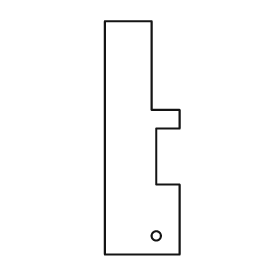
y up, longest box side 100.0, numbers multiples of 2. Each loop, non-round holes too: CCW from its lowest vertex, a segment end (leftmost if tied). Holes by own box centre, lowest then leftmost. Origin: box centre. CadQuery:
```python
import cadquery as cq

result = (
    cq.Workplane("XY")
    .moveTo(-16.0, -50.0)
    .lineTo(16.0, -50.0)
    .lineTo(16.0, -20.0)
    .lineTo(6.0, -20.0)
    .lineTo(6.0, 4.0)
    .lineTo(16.0, 4.0)
    .lineTo(16.0, 12.0)
    .lineTo(4.0, 12.0)
    .lineTo(4.0, 50.0)
    .lineTo(-16.0, 50.0)
    .close()
    .moveTo(6.0, -42.0)
    .circle(2.0)
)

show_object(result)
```